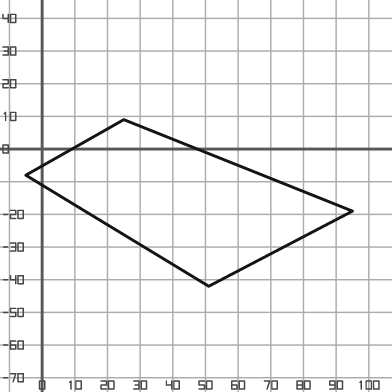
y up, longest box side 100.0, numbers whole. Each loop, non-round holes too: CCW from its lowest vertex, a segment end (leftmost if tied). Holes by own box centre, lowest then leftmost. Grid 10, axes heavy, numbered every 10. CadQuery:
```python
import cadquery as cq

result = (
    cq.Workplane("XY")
    .moveTo(51.0, -42.0)
    .lineTo(95.0, -19.0)
    .lineTo(25.0, 9.0)
    .lineTo(-5.0, -8.0)
    .close()
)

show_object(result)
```